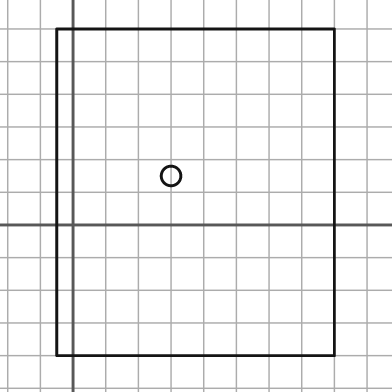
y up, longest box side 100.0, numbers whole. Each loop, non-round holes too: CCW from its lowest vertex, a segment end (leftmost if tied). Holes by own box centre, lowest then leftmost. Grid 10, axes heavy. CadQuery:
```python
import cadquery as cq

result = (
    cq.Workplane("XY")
    .moveTo(-5.0, -40.0)
    .lineTo(80.0, -40.0)
    .lineTo(80.0, 60.0)
    .lineTo(-5.0, 60.0)
    .close()
    .moveTo(30.0, 15.0)
    .circle(3.0)
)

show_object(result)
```